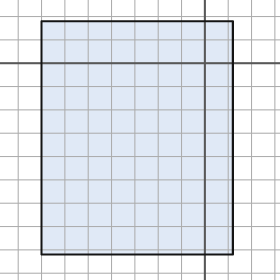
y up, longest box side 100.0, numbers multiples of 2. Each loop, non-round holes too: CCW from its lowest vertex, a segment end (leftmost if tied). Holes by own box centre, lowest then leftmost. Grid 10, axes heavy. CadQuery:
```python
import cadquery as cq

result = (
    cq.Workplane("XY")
    .moveTo(-70.0, -82.0)
    .lineTo(12.0, -82.0)
    .lineTo(12.0, 18.0)
    .lineTo(-70.0, 18.0)
    .close()
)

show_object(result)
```